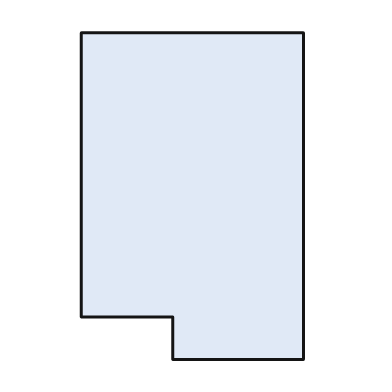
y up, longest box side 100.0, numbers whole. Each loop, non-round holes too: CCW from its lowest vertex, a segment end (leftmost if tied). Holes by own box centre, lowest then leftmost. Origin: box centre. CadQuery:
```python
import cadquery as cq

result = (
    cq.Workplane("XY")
    .moveTo(-6.0, -50.0)
    .lineTo(34.0, -50.0)
    .lineTo(34.0, 50.0)
    .lineTo(-34.0, 50.0)
    .lineTo(-34.0, -37.0)
    .lineTo(-6.0, -37.0)
    .close()
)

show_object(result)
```